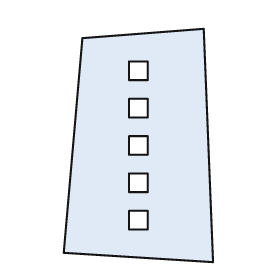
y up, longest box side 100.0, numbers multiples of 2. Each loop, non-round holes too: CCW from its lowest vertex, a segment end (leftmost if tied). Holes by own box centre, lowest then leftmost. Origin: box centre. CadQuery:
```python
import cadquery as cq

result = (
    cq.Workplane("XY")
    .moveTo(32.0, -50.0)
    .lineTo(28.0, 50.0)
    .lineTo(-24.0, 46.0)
    .lineTo(-32.0, -46.0)
    .close()
    .moveTo(-4.0, -36.0)
    .lineTo(4.0, -36.0)
    .lineTo(4.0, -28.0)
    .lineTo(-4.0, -28.0)
    .close()
    .moveTo(-4.0, -20.0)
    .lineTo(4.0, -20.0)
    .lineTo(4.0, -12.0)
    .lineTo(-4.0, -12.0)
    .close()
    .moveTo(-4.0, -4.0)
    .lineTo(4.0, -4.0)
    .lineTo(4.0, 4.0)
    .lineTo(-4.0, 4.0)
    .close()
    .moveTo(-4.0, 12.0)
    .lineTo(4.0, 12.0)
    .lineTo(4.0, 20.0)
    .lineTo(-4.0, 20.0)
    .close()
    .moveTo(-4.0, 28.0)
    .lineTo(4.0, 28.0)
    .lineTo(4.0, 36.0)
    .lineTo(-4.0, 36.0)
    .close()
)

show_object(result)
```